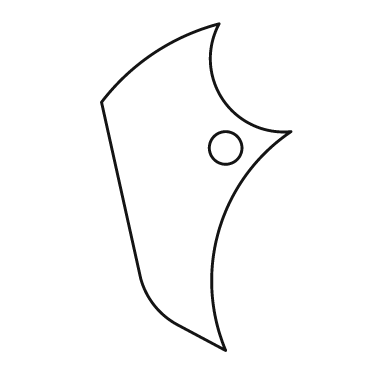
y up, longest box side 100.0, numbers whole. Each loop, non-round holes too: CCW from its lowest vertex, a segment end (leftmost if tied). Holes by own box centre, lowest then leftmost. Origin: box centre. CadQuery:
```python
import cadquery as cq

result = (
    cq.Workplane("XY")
    .moveTo(9.0, -50.0)
    .threePointArc((7.0, -13.0), (29.0, 17.0))
    .threePointArc((8.0, 27.0), (7.0, 50.0))
    .threePointArc((-13.0, 41.0), (-29.0, 26.0))
    .lineTo(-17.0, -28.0)
    .threePointArc((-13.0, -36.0), (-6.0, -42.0))
    .close()
    .moveTo(9.0, 12.0)
    .circle(5.0)
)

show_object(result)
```